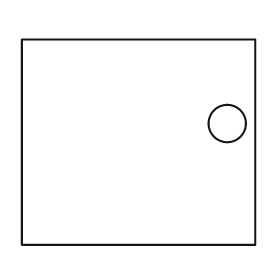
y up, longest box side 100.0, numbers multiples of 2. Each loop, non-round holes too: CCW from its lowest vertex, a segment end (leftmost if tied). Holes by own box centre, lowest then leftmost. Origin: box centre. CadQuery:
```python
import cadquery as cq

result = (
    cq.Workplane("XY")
    .moveTo(-50.0, -44.0)
    .lineTo(50.0, -44.0)
    .lineTo(50.0, 44.0)
    .lineTo(-50.0, 44.0)
    .close()
    .moveTo(38.0, 8.0)
    .circle(8.0)
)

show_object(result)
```